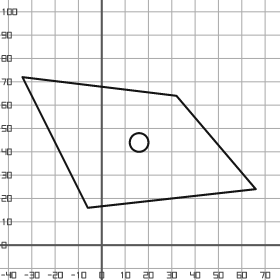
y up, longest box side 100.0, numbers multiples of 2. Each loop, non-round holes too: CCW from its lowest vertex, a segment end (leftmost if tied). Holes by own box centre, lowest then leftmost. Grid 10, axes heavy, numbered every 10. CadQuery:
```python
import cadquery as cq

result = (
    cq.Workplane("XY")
    .moveTo(-6.0, 16.0)
    .lineTo(66.0, 24.0)
    .lineTo(32.0, 64.0)
    .lineTo(-34.0, 72.0)
    .close()
    .moveTo(16.0, 44.0)
    .circle(4.0)
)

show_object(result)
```